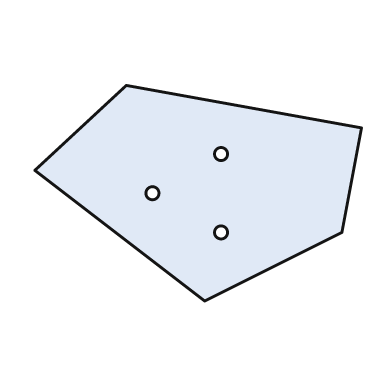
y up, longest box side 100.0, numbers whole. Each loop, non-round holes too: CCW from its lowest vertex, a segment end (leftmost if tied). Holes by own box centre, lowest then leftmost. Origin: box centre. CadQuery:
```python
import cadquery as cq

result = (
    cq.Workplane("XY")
    .moveTo(2.0, -33.0)
    .lineTo(44.0, -12.0)
    .lineTo(50.0, 20.0)
    .lineTo(-22.0, 33.0)
    .lineTo(-50.0, 7.0)
    .close()
    .moveTo(7.0, -12.0)
    .circle(2.0)
    .moveTo(-14.0, 0.0)
    .circle(2.0)
    .moveTo(7.0, 12.0)
    .circle(2.0)
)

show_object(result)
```